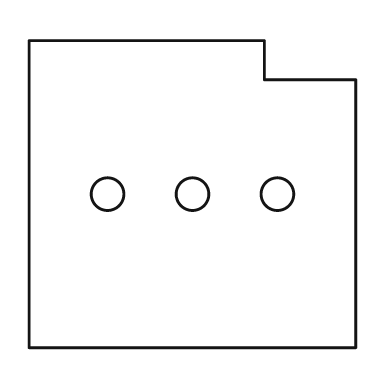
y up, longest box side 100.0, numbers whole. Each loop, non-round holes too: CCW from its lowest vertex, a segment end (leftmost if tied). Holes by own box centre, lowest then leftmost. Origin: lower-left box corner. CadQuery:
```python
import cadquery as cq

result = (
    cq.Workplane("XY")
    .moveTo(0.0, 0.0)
    .lineTo(100.0, 0.0)
    .lineTo(100.0, 82.0)
    .lineTo(72.0, 82.0)
    .lineTo(72.0, 94.0)
    .lineTo(0.0, 94.0)
    .close()
    .moveTo(24.0, 47.0)
    .circle(5.0)
    .moveTo(50.0, 47.0)
    .circle(5.0)
    .moveTo(76.0, 47.0)
    .circle(5.0)
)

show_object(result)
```